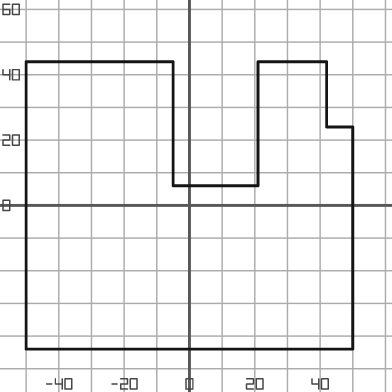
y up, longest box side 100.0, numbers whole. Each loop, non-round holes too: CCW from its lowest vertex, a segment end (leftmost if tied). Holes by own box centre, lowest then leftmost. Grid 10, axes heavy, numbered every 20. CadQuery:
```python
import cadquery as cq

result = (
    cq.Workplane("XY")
    .moveTo(-50.0, -44.0)
    .lineTo(50.0, -44.0)
    .lineTo(50.0, 24.0)
    .lineTo(42.0, 24.0)
    .lineTo(42.0, 44.0)
    .lineTo(21.0, 44.0)
    .lineTo(21.0, 6.0)
    .lineTo(-5.0, 6.0)
    .lineTo(-5.0, 44.0)
    .lineTo(-50.0, 44.0)
    .close()
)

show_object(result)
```